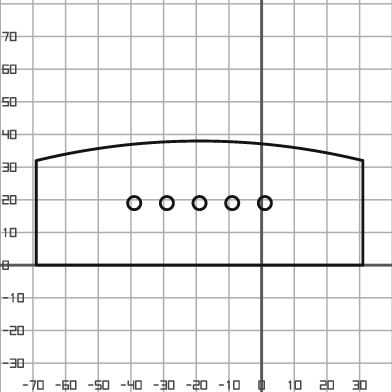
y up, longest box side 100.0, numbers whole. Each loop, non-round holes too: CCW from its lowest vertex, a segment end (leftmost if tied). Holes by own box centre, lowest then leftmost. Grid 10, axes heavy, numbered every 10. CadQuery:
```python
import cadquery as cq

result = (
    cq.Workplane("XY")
    .moveTo(-69.0, 0.0)
    .lineTo(31.0, 0.0)
    .lineTo(31.0, 32.0)
    .threePointArc((-19.0, 38.0), (-69.0, 32.0))
    .close()
    .moveTo(-39.0, 19.0)
    .circle(2.0)
    .moveTo(-29.0, 19.0)
    .circle(2.0)
    .moveTo(-19.0, 19.0)
    .circle(2.0)
    .moveTo(-9.0, 19.0)
    .circle(2.0)
    .moveTo(1.0, 19.0)
    .circle(2.0)
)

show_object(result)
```